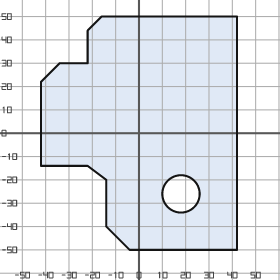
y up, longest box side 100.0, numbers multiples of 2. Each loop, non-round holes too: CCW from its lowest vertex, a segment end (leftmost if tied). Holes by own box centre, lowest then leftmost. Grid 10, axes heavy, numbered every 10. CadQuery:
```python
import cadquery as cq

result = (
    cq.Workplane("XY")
    .moveTo(-4.0, -50.0)
    .lineTo(42.0, -50.0)
    .lineTo(42.0, 50.0)
    .lineTo(-16.0, 50.0)
    .lineTo(-22.0, 44.0)
    .lineTo(-22.0, 30.0)
    .lineTo(-34.0, 30.0)
    .lineTo(-42.0, 22.0)
    .lineTo(-42.0, -14.0)
    .lineTo(-22.0, -14.0)
    .lineTo(-14.0, -20.0)
    .lineTo(-14.0, -40.0)
    .close()
    .moveTo(18.0, -26.0)
    .circle(8.0)
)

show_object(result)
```